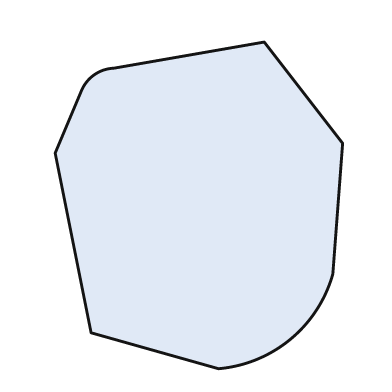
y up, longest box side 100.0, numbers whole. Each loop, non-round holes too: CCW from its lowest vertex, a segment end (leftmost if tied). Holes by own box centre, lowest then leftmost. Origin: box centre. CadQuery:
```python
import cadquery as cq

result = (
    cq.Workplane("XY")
    .moveTo(6.0, -50.0)
    .threePointArc((28.0, -41.0), (41.0, -21.0))
    .lineTo(44.0, 19.0)
    .lineTo(20.0, 50.0)
    .lineTo(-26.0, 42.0)
    .threePointArc((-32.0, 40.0), (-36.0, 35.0))
    .lineTo(-44.0, 16.0)
    .lineTo(-33.0, -39.0)
    .close()
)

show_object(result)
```